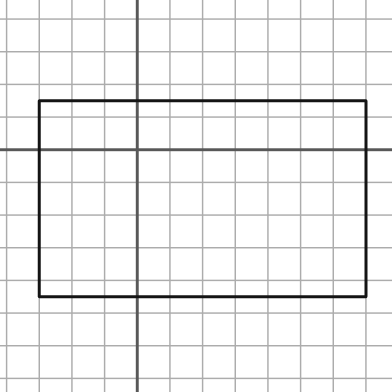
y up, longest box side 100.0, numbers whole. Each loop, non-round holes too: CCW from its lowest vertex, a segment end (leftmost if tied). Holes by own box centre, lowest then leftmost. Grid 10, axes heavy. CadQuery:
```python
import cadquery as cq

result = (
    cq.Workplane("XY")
    .moveTo(-30.0, -45.0)
    .lineTo(70.0, -45.0)
    .lineTo(70.0, 15.0)
    .lineTo(-30.0, 15.0)
    .close()
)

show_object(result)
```